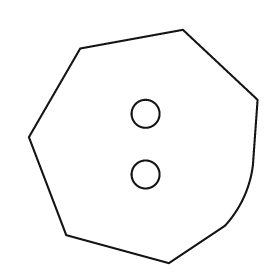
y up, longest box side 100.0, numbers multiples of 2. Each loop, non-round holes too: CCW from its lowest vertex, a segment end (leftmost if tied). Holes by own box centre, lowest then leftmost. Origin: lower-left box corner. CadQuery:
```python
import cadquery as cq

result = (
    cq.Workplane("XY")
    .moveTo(60.0, 0.0)
    .lineTo(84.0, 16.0)
    .threePointArc((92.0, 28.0), (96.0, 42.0))
    .lineTo(98.0, 70.0)
    .lineTo(66.0, 100.0)
    .lineTo(22.0, 92.0)
    .lineTo(0.0, 54.0)
    .lineTo(16.0, 12.0)
    .close()
    .moveTo(50.0, 38.0)
    .circle(6.0)
    .moveTo(50.0, 64.0)
    .circle(6.0)
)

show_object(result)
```